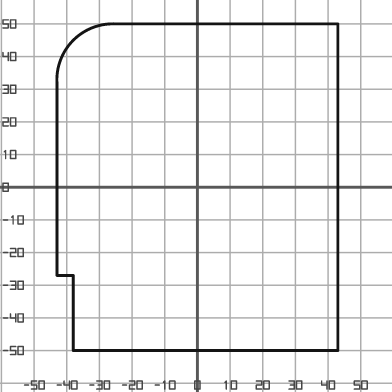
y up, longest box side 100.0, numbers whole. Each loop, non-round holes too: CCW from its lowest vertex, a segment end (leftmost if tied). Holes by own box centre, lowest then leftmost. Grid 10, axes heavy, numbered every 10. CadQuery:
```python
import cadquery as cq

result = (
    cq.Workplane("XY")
    .moveTo(-38.0, -50.0)
    .lineTo(43.0, -50.0)
    .lineTo(43.0, 50.0)
    .lineTo(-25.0, 50.0)
    .threePointArc((-38.0, 45.0), (-43.0, 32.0))
    .lineTo(-43.0, -27.0)
    .lineTo(-38.0, -27.0)
    .close()
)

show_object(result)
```